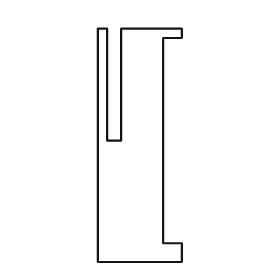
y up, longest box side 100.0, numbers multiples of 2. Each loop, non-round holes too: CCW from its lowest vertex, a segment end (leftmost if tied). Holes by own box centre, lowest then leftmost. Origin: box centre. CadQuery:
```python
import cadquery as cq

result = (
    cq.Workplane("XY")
    .moveTo(-18.0, -50.0)
    .lineTo(18.0, -50.0)
    .lineTo(18.0, -42.0)
    .lineTo(10.0, -42.0)
    .lineTo(10.0, 46.0)
    .lineTo(18.0, 46.0)
    .lineTo(18.0, 50.0)
    .lineTo(-8.0, 50.0)
    .lineTo(-8.0, 2.0)
    .lineTo(-14.0, 2.0)
    .lineTo(-14.0, 50.0)
    .lineTo(-18.0, 50.0)
    .close()
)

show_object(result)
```